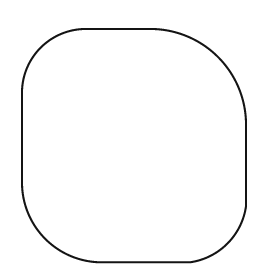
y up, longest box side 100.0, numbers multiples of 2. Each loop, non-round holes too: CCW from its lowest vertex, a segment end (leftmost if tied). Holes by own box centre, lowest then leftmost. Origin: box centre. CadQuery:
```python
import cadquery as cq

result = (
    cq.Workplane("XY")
    .moveTo(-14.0, -50.0)
    .lineTo(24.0, -50.0)
    .threePointArc((40.0, -42.0), (48.0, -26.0))
    .lineTo(48.0, 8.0)
    .threePointArc((36.0, 38.0), (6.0, 50.0))
    .lineTo(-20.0, 50.0)
    .threePointArc((-40.0, 42.0), (-48.0, 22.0))
    .lineTo(-48.0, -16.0)
    .threePointArc((-38.0, -40.0), (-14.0, -50.0))
    .close()
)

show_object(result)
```